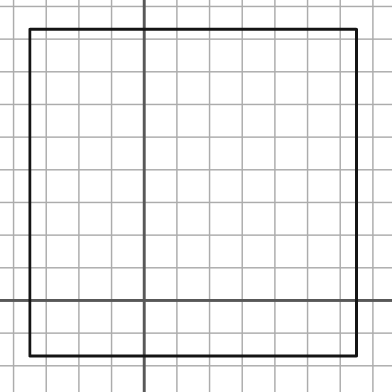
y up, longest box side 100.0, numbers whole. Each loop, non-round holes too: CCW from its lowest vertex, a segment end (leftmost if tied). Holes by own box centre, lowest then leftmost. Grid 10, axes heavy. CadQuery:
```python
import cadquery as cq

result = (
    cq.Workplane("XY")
    .moveTo(-35.0, -17.0)
    .lineTo(65.0, -17.0)
    .lineTo(65.0, 83.0)
    .lineTo(-35.0, 83.0)
    .close()
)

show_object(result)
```